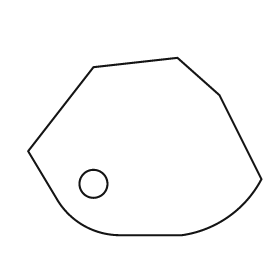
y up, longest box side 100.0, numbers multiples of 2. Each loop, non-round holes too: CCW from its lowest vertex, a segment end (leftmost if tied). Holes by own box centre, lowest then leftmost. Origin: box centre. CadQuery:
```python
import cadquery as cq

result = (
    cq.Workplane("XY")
    .moveTo(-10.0, -38.0)
    .lineTo(16.0, -38.0)
    .threePointArc((36.0, -30.0), (50.0, -14.0))
    .lineTo(32.0, 22.0)
    .lineTo(14.0, 38.0)
    .lineTo(-22.0, 34.0)
    .lineTo(-50.0, -2.0)
    .lineTo(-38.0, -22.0)
    .threePointArc((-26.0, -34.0), (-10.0, -38.0))
    .close()
    .moveTo(-22.0, -16.0)
    .circle(6.0)
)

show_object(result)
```